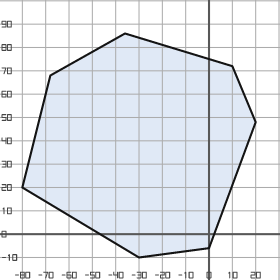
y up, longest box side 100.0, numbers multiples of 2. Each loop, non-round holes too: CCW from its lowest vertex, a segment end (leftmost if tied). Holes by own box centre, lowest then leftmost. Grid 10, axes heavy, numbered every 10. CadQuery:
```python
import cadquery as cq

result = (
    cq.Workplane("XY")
    .moveTo(-30.0, -10.0)
    .lineTo(0.0, -6.0)
    .lineTo(20.0, 48.0)
    .lineTo(10.0, 72.0)
    .lineTo(-36.0, 86.0)
    .lineTo(-68.0, 68.0)
    .lineTo(-80.0, 20.0)
    .close()
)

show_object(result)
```